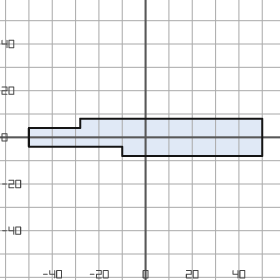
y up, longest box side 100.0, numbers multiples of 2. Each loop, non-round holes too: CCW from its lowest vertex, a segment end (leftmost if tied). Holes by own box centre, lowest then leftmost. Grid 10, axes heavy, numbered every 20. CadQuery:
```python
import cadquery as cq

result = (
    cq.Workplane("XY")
    .moveTo(-10.0, -8.0)
    .lineTo(50.0, -8.0)
    .lineTo(50.0, 8.0)
    .lineTo(-28.0, 8.0)
    .lineTo(-28.0, 4.0)
    .lineTo(-50.0, 4.0)
    .lineTo(-50.0, -4.0)
    .lineTo(-10.0, -4.0)
    .close()
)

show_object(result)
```